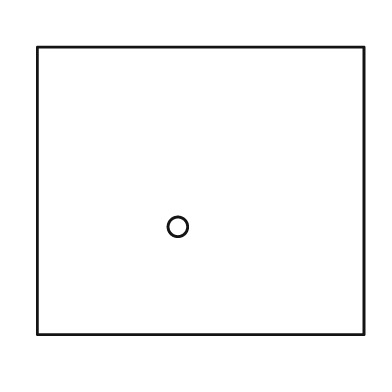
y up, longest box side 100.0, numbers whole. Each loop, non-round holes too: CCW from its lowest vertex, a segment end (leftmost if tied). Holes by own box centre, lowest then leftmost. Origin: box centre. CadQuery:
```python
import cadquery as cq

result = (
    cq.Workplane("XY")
    .moveTo(-50.0, -44.0)
    .lineTo(50.0, -44.0)
    .lineTo(50.0, 44.0)
    .lineTo(-50.0, 44.0)
    .close()
    .moveTo(-7.0, -11.0)
    .circle(3.0)
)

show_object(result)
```